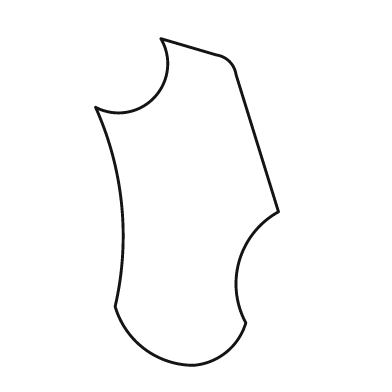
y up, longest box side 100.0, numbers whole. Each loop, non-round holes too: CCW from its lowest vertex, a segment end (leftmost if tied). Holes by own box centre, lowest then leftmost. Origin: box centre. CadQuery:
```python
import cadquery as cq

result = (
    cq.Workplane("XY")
    .moveTo(2.0, -50.0)
    .threePointArc((12.0, -46.0), (18.0, -37.0))
    .threePointArc((16.0, -18.0), (28.0, -3.0))
    .lineTo(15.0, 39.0)
    .threePointArc((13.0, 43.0), (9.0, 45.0))
    .lineTo(-8.0, 50.0)
    .threePointArc((-10.0, 32.0), (-28.0, 29.0))
    .threePointArc((-20.0, -1.0), (-22.0, -32.0))
    .threePointArc((-13.0, -45.0), (2.0, -50.0))
    .close()
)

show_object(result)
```